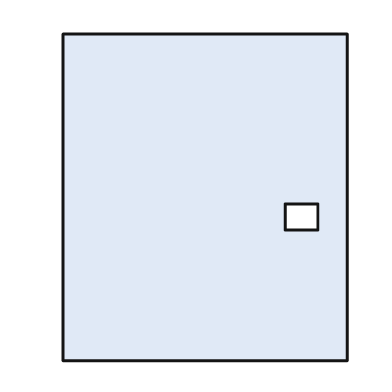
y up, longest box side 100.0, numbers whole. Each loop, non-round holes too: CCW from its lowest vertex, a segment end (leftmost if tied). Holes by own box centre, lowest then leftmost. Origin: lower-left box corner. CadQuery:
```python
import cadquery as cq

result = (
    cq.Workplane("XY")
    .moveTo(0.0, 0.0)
    .lineTo(87.0, 0.0)
    .lineTo(87.0, 100.0)
    .lineTo(0.0, 100.0)
    .close()
    .moveTo(68.0, 40.0)
    .lineTo(78.0, 40.0)
    .lineTo(78.0, 48.0)
    .lineTo(68.0, 48.0)
    .close()
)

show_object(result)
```